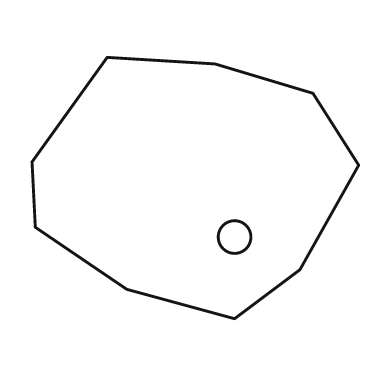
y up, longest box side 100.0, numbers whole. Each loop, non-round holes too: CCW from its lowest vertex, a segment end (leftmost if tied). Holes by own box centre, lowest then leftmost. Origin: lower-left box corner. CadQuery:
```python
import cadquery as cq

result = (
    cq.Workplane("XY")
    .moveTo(62.0, 0.0)
    .lineTo(82.0, 15.0)
    .lineTo(100.0, 47.0)
    .lineTo(86.0, 69.0)
    .lineTo(56.0, 78.0)
    .lineTo(23.0, 80.0)
    .lineTo(0.0, 48.0)
    .lineTo(1.0, 28.0)
    .lineTo(29.0, 9.0)
    .close()
    .moveTo(62.0, 25.0)
    .circle(5.0)
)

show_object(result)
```